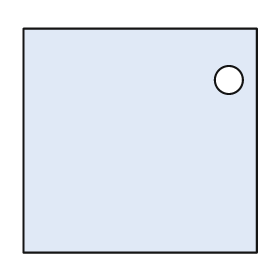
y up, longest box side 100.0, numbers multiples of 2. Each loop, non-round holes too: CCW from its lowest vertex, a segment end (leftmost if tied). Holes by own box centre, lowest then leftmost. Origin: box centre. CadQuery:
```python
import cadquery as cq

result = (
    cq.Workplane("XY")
    .moveTo(-50.0, -48.0)
    .lineTo(50.0, -48.0)
    .lineTo(50.0, 48.0)
    .lineTo(-50.0, 48.0)
    .close()
    .moveTo(38.0, 26.0)
    .circle(6.0)
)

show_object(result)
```